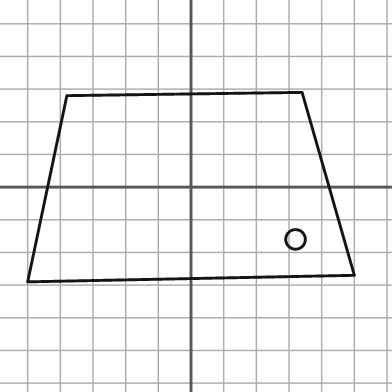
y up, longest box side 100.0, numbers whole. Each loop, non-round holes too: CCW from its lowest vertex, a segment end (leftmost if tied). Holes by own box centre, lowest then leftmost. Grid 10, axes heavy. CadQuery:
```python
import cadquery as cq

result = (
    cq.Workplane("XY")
    .moveTo(-50.0, -29.0)
    .lineTo(50.0, -27.0)
    .lineTo(34.0, 29.0)
    .lineTo(-38.0, 28.0)
    .close()
    .moveTo(32.0, -16.0)
    .circle(3.0)
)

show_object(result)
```